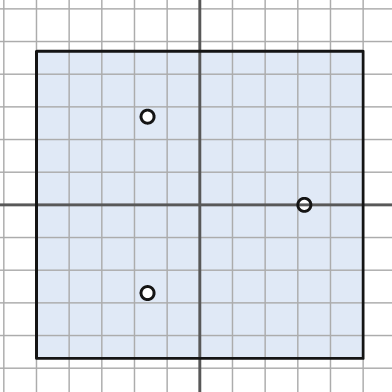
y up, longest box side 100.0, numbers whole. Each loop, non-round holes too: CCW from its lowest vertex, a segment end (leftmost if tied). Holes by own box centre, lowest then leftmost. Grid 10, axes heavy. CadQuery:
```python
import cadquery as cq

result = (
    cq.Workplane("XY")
    .moveTo(-50.0, -47.0)
    .lineTo(50.0, -47.0)
    .lineTo(50.0, 47.0)
    .lineTo(-50.0, 47.0)
    .close()
    .moveTo(-16.0, -27.0)
    .circle(2.0)
    .moveTo(32.0, 0.0)
    .circle(2.0)
    .moveTo(-16.0, 27.0)
    .circle(2.0)
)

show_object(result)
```